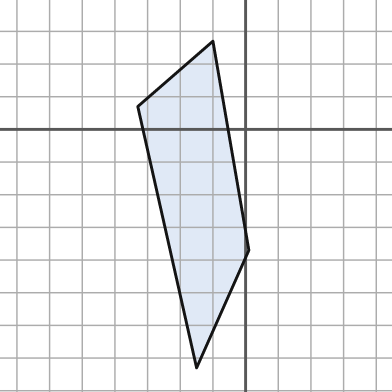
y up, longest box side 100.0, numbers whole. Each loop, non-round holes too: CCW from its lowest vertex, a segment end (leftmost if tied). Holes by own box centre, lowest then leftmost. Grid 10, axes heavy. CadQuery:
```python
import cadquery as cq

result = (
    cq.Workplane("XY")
    .moveTo(-15.0, -73.0)
    .lineTo(1.0, -37.0)
    .lineTo(-10.0, 27.0)
    .lineTo(-33.0, 7.0)
    .close()
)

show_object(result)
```